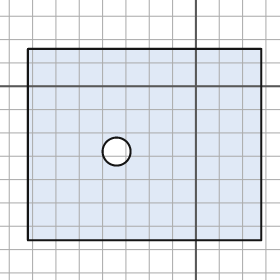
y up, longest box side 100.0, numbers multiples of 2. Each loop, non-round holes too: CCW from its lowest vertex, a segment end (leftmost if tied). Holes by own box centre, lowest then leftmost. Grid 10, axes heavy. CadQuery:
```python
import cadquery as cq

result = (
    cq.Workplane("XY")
    .moveTo(-72.0, -66.0)
    .lineTo(28.0, -66.0)
    .lineTo(28.0, 16.0)
    .lineTo(-72.0, 16.0)
    .close()
    .moveTo(-34.0, -28.0)
    .circle(6.0)
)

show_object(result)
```